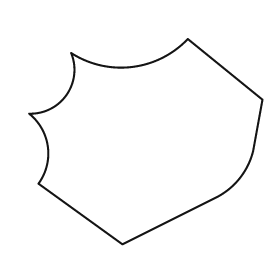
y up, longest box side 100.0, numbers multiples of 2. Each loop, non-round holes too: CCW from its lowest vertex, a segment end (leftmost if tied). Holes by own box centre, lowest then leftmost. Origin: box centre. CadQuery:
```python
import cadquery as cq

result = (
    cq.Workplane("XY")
    .moveTo(-10.0, -44.0)
    .lineTo(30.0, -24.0)
    .threePointArc((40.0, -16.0), (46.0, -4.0))
    .lineTo(50.0, 18.0)
    .lineTo(18.0, 44.0)
    .threePointArc((-6.0, 32.0), (-32.0, 38.0))
    .threePointArc((-34.0, 20.0), (-50.0, 12.0))
    .threePointArc((-42.0, -2.0), (-46.0, -18.0))
    .close()
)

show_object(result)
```